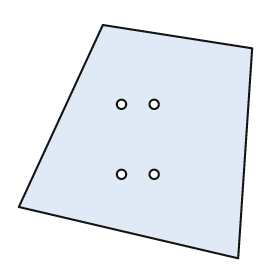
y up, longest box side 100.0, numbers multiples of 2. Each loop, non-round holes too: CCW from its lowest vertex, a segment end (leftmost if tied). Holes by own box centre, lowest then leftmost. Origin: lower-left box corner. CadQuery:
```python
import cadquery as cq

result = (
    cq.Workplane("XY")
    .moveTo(94.0, 0.0)
    .lineTo(100.0, 90.0)
    .lineTo(36.0, 100.0)
    .lineTo(0.0, 22.0)
    .close()
    .moveTo(44.0, 36.0)
    .circle(2.0)
    .moveTo(58.0, 36.0)
    .circle(2.0)
    .moveTo(44.0, 66.0)
    .circle(2.0)
    .moveTo(58.0, 66.0)
    .circle(2.0)
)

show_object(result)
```